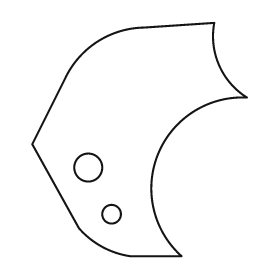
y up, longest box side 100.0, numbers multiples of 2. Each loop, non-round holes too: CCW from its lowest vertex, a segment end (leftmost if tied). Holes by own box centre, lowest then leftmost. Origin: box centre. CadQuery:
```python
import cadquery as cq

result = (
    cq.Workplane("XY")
    .moveTo(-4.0, -50.0)
    .lineTo(18.0, -50.0)
    .threePointArc((8.0, -6.0), (46.0, 18.0))
    .threePointArc((34.0, 32.0), (32.0, 50.0))
    .lineTo(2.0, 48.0)
    .threePointArc((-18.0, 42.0), (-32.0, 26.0))
    .lineTo(-46.0, -2.0)
    .lineTo(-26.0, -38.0)
    .threePointArc((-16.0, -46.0), (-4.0, -50.0))
    .close()
    .moveTo(-12.0, -32.0)
    .circle(4.0)
    .moveTo(-22.0, -12.0)
    .circle(6.0)
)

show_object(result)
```